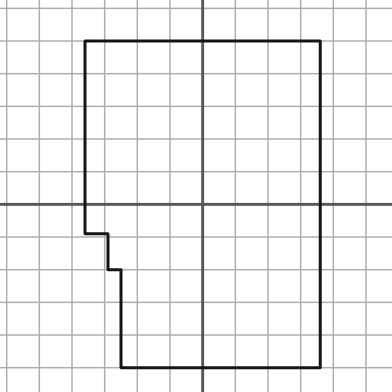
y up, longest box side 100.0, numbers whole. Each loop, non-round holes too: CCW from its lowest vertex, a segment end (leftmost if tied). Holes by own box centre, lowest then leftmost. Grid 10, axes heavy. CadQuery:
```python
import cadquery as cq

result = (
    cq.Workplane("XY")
    .moveTo(-25.0, -50.0)
    .lineTo(36.0, -50.0)
    .lineTo(36.0, 50.0)
    .lineTo(-36.0, 50.0)
    .lineTo(-36.0, -9.0)
    .lineTo(-29.0, -9.0)
    .lineTo(-29.0, -20.0)
    .lineTo(-25.0, -20.0)
    .close()
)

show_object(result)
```